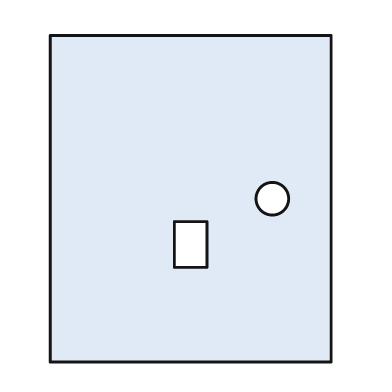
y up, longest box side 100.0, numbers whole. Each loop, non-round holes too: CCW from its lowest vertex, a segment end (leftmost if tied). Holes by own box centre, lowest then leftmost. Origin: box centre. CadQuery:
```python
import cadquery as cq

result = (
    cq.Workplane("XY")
    .moveTo(-43.0, -50.0)
    .lineTo(43.0, -50.0)
    .lineTo(43.0, 50.0)
    .lineTo(-43.0, 50.0)
    .close()
    .moveTo(-5.0, -21.0)
    .lineTo(5.0, -21.0)
    .lineTo(5.0, -7.0)
    .lineTo(-5.0, -7.0)
    .close()
    .moveTo(25.0, 0.0)
    .circle(5.0)
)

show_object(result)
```